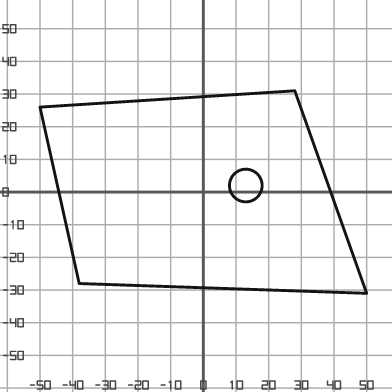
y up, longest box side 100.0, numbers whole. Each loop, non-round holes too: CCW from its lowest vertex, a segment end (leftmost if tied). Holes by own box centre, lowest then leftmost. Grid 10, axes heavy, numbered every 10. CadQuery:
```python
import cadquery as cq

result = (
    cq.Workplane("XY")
    .moveTo(50.0, -31.0)
    .lineTo(28.0, 31.0)
    .lineTo(-50.0, 26.0)
    .lineTo(-38.0, -28.0)
    .close()
    .moveTo(13.0, 2.0)
    .circle(5.0)
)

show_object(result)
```